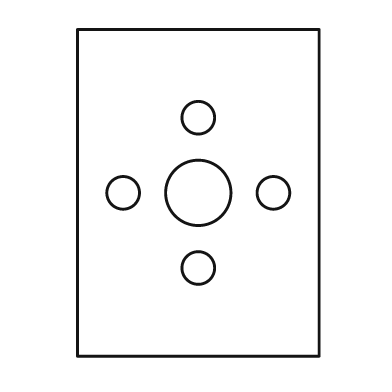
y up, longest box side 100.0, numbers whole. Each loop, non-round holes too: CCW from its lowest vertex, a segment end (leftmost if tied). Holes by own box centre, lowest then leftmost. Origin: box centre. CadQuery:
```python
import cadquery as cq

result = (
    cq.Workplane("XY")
    .moveTo(-37.0, -50.0)
    .lineTo(37.0, -50.0)
    .lineTo(37.0, 50.0)
    .lineTo(-37.0, 50.0)
    .close()
    .moveTo(0.0, -23.0)
    .circle(5.0)
    .moveTo(-23.0, 0.0)
    .circle(5.0)
    .moveTo(0.0, 0.0)
    .circle(10.0)
    .moveTo(23.0, 0.0)
    .circle(5.0)
    .moveTo(0.0, 23.0)
    .circle(5.0)
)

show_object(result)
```